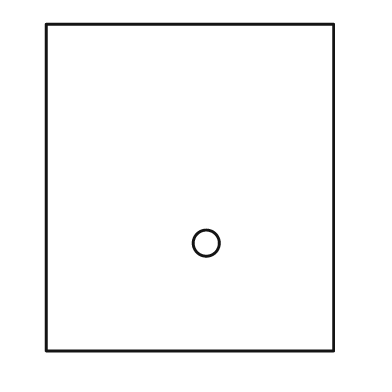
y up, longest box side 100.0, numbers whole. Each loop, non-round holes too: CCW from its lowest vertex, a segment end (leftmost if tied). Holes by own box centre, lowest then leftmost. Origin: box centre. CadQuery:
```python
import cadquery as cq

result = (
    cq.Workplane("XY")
    .moveTo(-44.0, -50.0)
    .lineTo(44.0, -50.0)
    .lineTo(44.0, 50.0)
    .lineTo(-44.0, 50.0)
    .close()
    .moveTo(5.0, -17.0)
    .circle(4.0)
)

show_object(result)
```